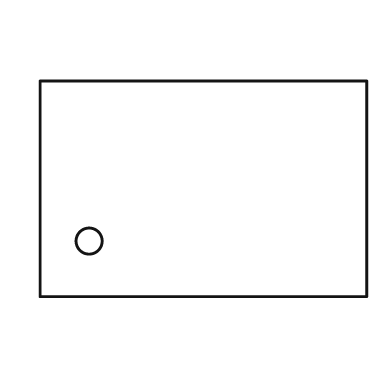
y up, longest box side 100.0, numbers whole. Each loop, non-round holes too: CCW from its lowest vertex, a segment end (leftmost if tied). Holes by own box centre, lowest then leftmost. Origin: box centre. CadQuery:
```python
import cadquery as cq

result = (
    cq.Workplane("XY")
    .moveTo(-50.0, -33.0)
    .lineTo(50.0, -33.0)
    .lineTo(50.0, 33.0)
    .lineTo(-50.0, 33.0)
    .close()
    .moveTo(-35.0, -16.0)
    .circle(4.0)
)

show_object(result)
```